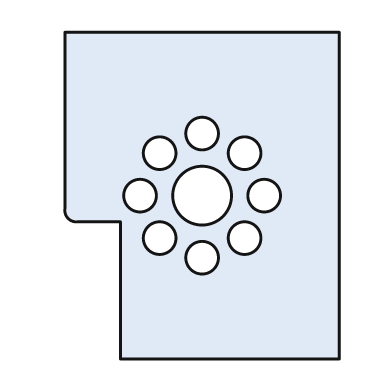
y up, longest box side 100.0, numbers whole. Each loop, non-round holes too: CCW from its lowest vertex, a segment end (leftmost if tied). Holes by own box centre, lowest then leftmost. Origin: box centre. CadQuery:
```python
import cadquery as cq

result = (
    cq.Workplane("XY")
    .moveTo(-25.0, -50.0)
    .lineTo(42.0, -50.0)
    .lineTo(42.0, 50.0)
    .lineTo(-42.0, 50.0)
    .lineTo(-42.0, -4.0)
    .threePointArc((-41.0, -7.0), (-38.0, -8.0))
    .lineTo(-25.0, -8.0)
    .close()
    .moveTo(0.0, -19.0)
    .circle(5.0)
    .moveTo(-13.0, -13.0)
    .circle(5.0)
    .moveTo(13.0, -13.0)
    .circle(5.0)
    .moveTo(-19.0, 0.0)
    .circle(5.0)
    .moveTo(0.0, 0.0)
    .circle(9.0)
    .moveTo(19.0, 0.0)
    .circle(5.0)
    .moveTo(-13.0, 13.0)
    .circle(5.0)
    .moveTo(13.0, 13.0)
    .circle(5.0)
    .moveTo(0.0, 19.0)
    .circle(5.0)
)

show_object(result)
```